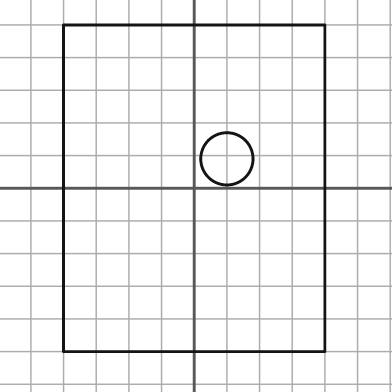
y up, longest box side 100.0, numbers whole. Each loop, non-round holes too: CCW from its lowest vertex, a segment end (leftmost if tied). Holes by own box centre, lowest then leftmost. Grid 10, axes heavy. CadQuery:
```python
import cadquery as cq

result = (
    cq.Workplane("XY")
    .moveTo(-40.0, -50.0)
    .lineTo(40.0, -50.0)
    .lineTo(40.0, 50.0)
    .lineTo(-40.0, 50.0)
    .close()
    .moveTo(10.0, 9.0)
    .circle(8.0)
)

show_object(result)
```